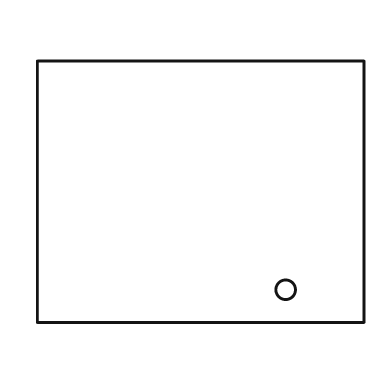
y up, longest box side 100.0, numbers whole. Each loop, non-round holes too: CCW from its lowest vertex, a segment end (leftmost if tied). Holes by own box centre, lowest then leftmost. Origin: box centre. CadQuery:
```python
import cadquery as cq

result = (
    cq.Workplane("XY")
    .moveTo(-50.0, -40.0)
    .lineTo(50.0, -40.0)
    .lineTo(50.0, 40.0)
    .lineTo(-50.0, 40.0)
    .close()
    .moveTo(26.0, -30.0)
    .circle(3.0)
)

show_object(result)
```